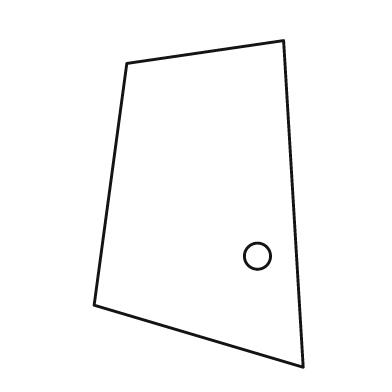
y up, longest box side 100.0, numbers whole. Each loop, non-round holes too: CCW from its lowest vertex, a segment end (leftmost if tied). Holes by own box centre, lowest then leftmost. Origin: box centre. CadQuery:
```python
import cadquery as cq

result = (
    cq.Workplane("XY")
    .moveTo(32.0, -50.0)
    .lineTo(26.0, 50.0)
    .lineTo(-22.0, 43.0)
    .lineTo(-32.0, -31.0)
    .close()
    .moveTo(18.0, -16.0)
    .circle(4.0)
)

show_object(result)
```